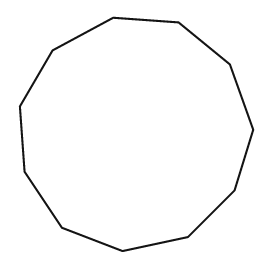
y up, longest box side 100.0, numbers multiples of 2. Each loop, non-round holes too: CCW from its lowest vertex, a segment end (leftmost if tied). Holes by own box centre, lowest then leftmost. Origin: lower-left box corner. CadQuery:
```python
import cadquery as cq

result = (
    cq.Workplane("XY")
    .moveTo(44.0, 0.0)
    .lineTo(72.0, 6.0)
    .lineTo(92.0, 26.0)
    .lineTo(100.0, 52.0)
    .lineTo(90.0, 80.0)
    .lineTo(68.0, 98.0)
    .lineTo(40.0, 100.0)
    .lineTo(14.0, 86.0)
    .lineTo(0.0, 62.0)
    .lineTo(2.0, 34.0)
    .lineTo(18.0, 10.0)
    .close()
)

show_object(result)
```